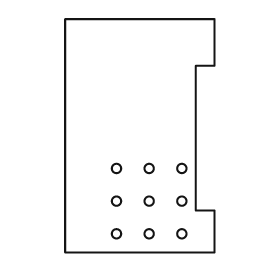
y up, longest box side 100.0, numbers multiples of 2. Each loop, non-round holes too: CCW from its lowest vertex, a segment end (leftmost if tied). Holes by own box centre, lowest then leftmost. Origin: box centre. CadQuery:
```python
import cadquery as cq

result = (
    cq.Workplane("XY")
    .moveTo(-32.0, -50.0)
    .lineTo(32.0, -50.0)
    .lineTo(32.0, -32.0)
    .lineTo(24.0, -32.0)
    .lineTo(24.0, 30.0)
    .lineTo(32.0, 30.0)
    .lineTo(32.0, 50.0)
    .lineTo(-32.0, 50.0)
    .close()
    .moveTo(-10.0, -42.0)
    .circle(2.0)
    .moveTo(4.0, -42.0)
    .circle(2.0)
    .moveTo(18.0, -42.0)
    .circle(2.0)
    .moveTo(-10.0, -28.0)
    .circle(2.0)
    .moveTo(4.0, -28.0)
    .circle(2.0)
    .moveTo(18.0, -28.0)
    .circle(2.0)
    .moveTo(-10.0, -14.0)
    .circle(2.0)
    .moveTo(4.0, -14.0)
    .circle(2.0)
    .moveTo(18.0, -14.0)
    .circle(2.0)
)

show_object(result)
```